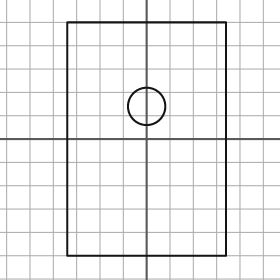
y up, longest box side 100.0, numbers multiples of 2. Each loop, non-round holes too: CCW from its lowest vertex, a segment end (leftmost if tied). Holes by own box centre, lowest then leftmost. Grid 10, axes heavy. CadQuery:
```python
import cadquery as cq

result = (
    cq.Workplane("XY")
    .moveTo(-34.0, -50.0)
    .lineTo(34.0, -50.0)
    .lineTo(34.0, 50.0)
    .lineTo(-34.0, 50.0)
    .close()
    .moveTo(0.0, 14.0)
    .circle(8.0)
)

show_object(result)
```